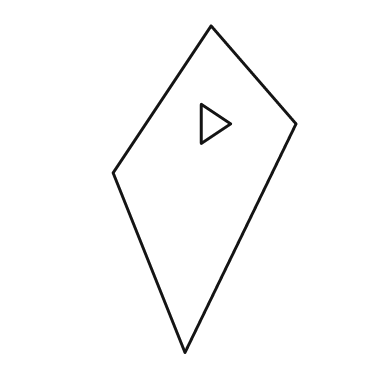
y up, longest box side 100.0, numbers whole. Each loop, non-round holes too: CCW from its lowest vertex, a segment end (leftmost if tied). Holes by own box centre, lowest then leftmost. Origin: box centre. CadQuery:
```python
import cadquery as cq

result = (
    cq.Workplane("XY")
    .moveTo(-6.0, -50.0)
    .lineTo(28.0, 20.0)
    .lineTo(2.0, 50.0)
    .lineTo(-28.0, 5.0)
    .close()
    .moveTo(-1.0, 14.0)
    .lineTo(8.0, 20.0)
    .lineTo(-1.0, 26.0)
    .close()
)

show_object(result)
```